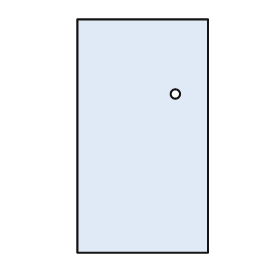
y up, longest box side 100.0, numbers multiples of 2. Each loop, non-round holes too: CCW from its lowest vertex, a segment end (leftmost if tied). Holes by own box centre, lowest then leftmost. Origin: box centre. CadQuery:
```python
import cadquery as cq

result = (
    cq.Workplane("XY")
    .moveTo(-28.0, -50.0)
    .lineTo(28.0, -50.0)
    .lineTo(28.0, 50.0)
    .lineTo(-28.0, 50.0)
    .close()
    .moveTo(14.0, 18.0)
    .circle(2.0)
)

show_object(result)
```